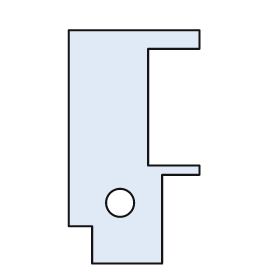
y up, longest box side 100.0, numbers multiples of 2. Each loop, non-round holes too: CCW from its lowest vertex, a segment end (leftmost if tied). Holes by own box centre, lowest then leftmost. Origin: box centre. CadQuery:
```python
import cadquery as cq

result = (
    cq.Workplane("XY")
    .moveTo(-18.0, -50.0)
    .lineTo(12.0, -50.0)
    .lineTo(12.0, -12.0)
    .lineTo(28.0, -12.0)
    .lineTo(28.0, -8.0)
    .lineTo(6.0, -8.0)
    .lineTo(6.0, 42.0)
    .lineTo(28.0, 42.0)
    .lineTo(28.0, 50.0)
    .lineTo(-28.0, 50.0)
    .lineTo(-28.0, -34.0)
    .lineTo(-18.0, -34.0)
    .close()
    .moveTo(-6.0, -24.0)
    .circle(6.0)
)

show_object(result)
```